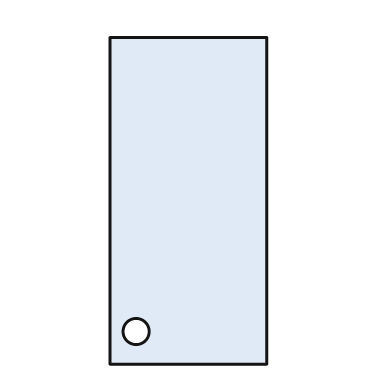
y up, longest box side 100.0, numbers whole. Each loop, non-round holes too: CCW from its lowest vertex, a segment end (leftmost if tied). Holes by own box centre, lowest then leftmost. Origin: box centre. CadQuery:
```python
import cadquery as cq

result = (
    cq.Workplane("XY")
    .moveTo(-24.0, -50.0)
    .lineTo(24.0, -50.0)
    .lineTo(24.0, 50.0)
    .lineTo(-24.0, 50.0)
    .close()
    .moveTo(-16.0, -40.0)
    .circle(4.0)
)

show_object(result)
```